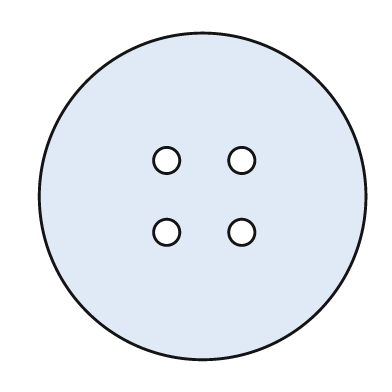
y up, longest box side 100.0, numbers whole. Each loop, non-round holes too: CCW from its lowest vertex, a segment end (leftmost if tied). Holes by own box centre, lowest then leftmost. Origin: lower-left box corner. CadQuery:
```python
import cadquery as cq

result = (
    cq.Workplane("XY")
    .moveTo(50.0, 50.0)
    .circle(50.0)
    .moveTo(39.0, 39.0)
    .circle(4.0)
    .moveTo(62.0, 39.0)
    .circle(4.0)
    .moveTo(39.0, 61.0)
    .circle(4.0)
    .moveTo(62.0, 61.0)
    .circle(4.0)
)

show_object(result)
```